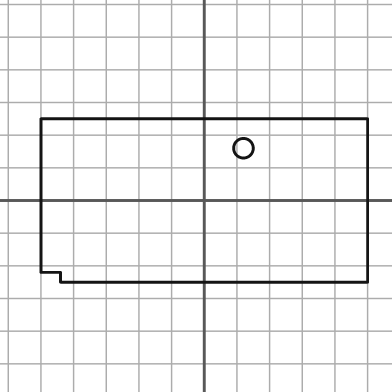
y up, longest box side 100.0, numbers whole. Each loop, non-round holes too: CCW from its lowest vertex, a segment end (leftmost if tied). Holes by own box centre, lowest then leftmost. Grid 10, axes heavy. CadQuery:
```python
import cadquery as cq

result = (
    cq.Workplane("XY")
    .moveTo(-44.0, -25.0)
    .lineTo(50.0, -25.0)
    .lineTo(50.0, 25.0)
    .lineTo(-50.0, 25.0)
    .lineTo(-50.0, -22.0)
    .lineTo(-44.0, -22.0)
    .close()
    .moveTo(12.0, 16.0)
    .circle(3.0)
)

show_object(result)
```